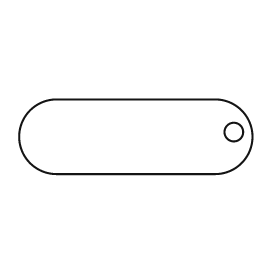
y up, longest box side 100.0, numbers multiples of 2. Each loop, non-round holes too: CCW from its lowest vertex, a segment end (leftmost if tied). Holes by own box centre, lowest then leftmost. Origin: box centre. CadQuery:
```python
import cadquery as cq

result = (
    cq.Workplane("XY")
    .moveTo(-34.0, -16.0)
    .lineTo(34.0, -16.0)
    .threePointArc((50.0, 0.0), (34.0, 16.0))
    .lineTo(-34.0, 16.0)
    .threePointArc((-50.0, 0.0), (-34.0, -16.0))
    .close()
    .moveTo(42.0, 2.0)
    .circle(4.0)
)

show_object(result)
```